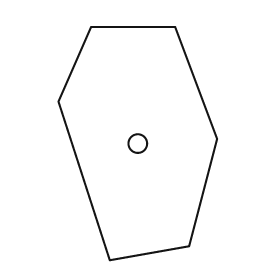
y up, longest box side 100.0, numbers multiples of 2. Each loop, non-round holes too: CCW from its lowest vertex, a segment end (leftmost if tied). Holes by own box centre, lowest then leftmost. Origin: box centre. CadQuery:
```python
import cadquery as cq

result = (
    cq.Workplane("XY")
    .moveTo(-12.0, -50.0)
    .lineTo(22.0, -44.0)
    .lineTo(34.0, 2.0)
    .lineTo(16.0, 50.0)
    .lineTo(-20.0, 50.0)
    .lineTo(-34.0, 18.0)
    .close()
    .moveTo(0.0, 0.0)
    .circle(4.0)
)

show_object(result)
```